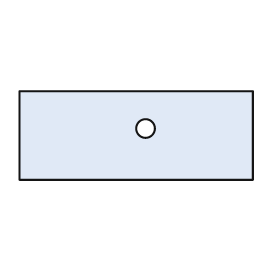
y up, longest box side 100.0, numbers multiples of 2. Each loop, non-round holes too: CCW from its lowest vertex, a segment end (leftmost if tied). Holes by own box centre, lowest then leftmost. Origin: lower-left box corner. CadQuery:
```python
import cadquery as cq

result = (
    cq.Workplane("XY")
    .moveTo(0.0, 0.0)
    .lineTo(100.0, 0.0)
    .lineTo(100.0, 38.0)
    .lineTo(0.0, 38.0)
    .close()
    .moveTo(54.0, 22.0)
    .circle(4.0)
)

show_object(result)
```